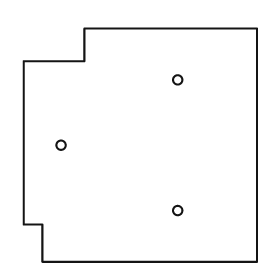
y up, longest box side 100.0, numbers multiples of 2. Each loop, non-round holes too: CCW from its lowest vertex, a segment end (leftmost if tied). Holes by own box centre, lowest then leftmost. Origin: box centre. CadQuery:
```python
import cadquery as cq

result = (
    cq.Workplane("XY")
    .moveTo(-42.0, -50.0)
    .lineTo(50.0, -50.0)
    .lineTo(50.0, 50.0)
    .lineTo(-24.0, 50.0)
    .lineTo(-24.0, 36.0)
    .lineTo(-50.0, 36.0)
    .lineTo(-50.0, -34.0)
    .lineTo(-42.0, -34.0)
    .close()
    .moveTo(16.0, -28.0)
    .circle(2.0)
    .moveTo(-34.0, 0.0)
    .circle(2.0)
    .moveTo(16.0, 28.0)
    .circle(2.0)
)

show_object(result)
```